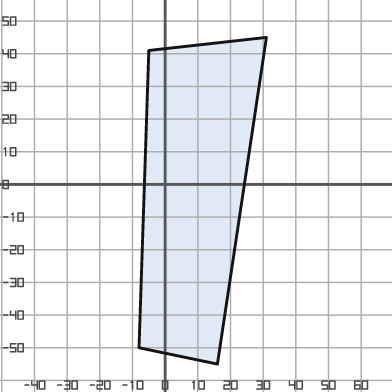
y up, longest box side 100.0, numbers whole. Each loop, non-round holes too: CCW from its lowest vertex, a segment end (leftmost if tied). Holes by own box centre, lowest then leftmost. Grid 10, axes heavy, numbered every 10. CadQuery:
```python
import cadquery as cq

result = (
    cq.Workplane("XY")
    .moveTo(16.0, -55.0)
    .lineTo(31.0, 45.0)
    .lineTo(-5.0, 41.0)
    .lineTo(-8.0, -50.0)
    .close()
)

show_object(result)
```